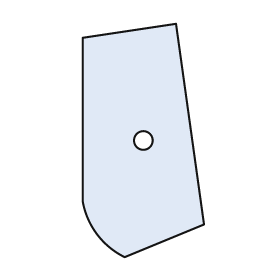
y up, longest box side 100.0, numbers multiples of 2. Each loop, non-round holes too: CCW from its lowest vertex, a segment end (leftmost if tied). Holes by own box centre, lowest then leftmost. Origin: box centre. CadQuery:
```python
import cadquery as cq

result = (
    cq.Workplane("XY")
    .moveTo(-8.0, -50.0)
    .lineTo(26.0, -36.0)
    .lineTo(14.0, 50.0)
    .lineTo(-26.0, 44.0)
    .lineTo(-26.0, -26.0)
    .threePointArc((-20.0, -40.0), (-8.0, -50.0))
    .close()
    .moveTo(0.0, 0.0)
    .circle(4.0)
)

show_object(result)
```